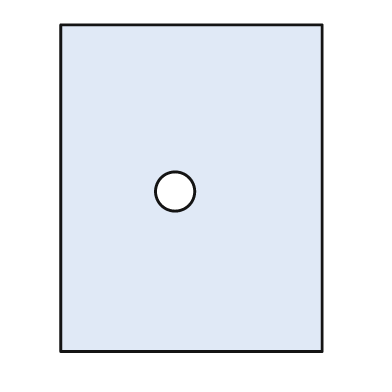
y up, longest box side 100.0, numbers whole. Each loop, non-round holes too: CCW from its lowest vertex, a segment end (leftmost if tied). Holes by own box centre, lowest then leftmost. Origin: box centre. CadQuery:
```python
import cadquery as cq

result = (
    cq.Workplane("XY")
    .moveTo(-40.0, -50.0)
    .lineTo(40.0, -50.0)
    .lineTo(40.0, 50.0)
    .lineTo(-40.0, 50.0)
    .close()
    .moveTo(-5.0, -1.0)
    .circle(6.0)
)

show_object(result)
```